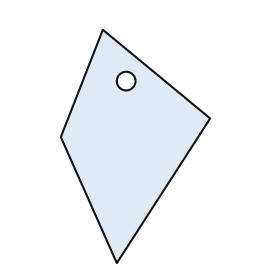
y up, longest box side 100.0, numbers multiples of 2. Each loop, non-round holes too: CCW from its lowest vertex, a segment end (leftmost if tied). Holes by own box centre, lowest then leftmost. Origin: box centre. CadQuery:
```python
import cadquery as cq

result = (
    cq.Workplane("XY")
    .moveTo(-8.0, -50.0)
    .lineTo(32.0, 12.0)
    .lineTo(-14.0, 50.0)
    .lineTo(-32.0, 4.0)
    .close()
    .moveTo(-4.0, 28.0)
    .circle(4.0)
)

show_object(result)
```